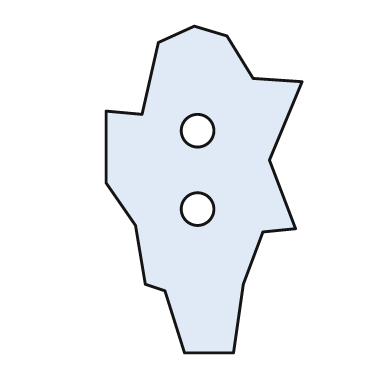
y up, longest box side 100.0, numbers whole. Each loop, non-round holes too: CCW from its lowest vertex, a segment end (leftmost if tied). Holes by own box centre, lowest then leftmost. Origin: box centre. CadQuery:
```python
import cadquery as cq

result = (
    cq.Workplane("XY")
    .moveTo(-6.0, -50.0)
    .lineTo(9.0, -50.0)
    .lineTo(12.0, -29.0)
    .lineTo(18.0, -13.0)
    .lineTo(28.0, -12.0)
    .lineTo(20.0, 9.0)
    .lineTo(30.0, 33.0)
    .lineTo(15.0, 34.0)
    .lineTo(7.0, 47.0)
    .lineTo(-3.0, 50.0)
    .lineTo(-14.0, 45.0)
    .lineTo(-19.0, 23.0)
    .lineTo(-30.0, 24.0)
    .lineTo(-30.0, 2.0)
    .lineTo(-21.0, -11.0)
    .lineTo(-18.0, -29.0)
    .lineTo(-12.0, -31.0)
    .close()
    .moveTo(-2.0, -6.0)
    .circle(5.0)
    .moveTo(-2.0, 18.0)
    .circle(5.0)
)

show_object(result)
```